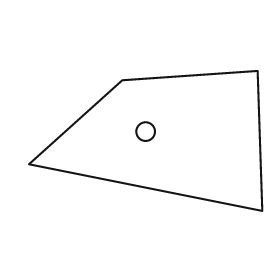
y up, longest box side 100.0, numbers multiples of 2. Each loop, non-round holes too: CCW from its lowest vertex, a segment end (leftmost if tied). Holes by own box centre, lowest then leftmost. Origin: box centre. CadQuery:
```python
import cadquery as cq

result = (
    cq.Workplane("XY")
    .moveTo(50.0, -30.0)
    .lineTo(48.0, 30.0)
    .lineTo(-10.0, 26.0)
    .lineTo(-50.0, -10.0)
    .close()
    .moveTo(0.0, 4.0)
    .circle(4.0)
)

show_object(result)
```